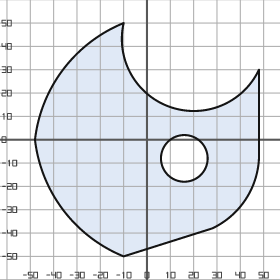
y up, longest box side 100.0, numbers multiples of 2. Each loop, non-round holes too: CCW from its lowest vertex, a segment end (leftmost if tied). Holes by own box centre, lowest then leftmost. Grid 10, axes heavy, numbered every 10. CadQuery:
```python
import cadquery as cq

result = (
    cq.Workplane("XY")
    .moveTo(-10.0, -50.0)
    .lineTo(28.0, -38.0)
    .threePointArc((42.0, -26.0), (48.0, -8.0))
    .lineTo(48.0, 30.0)
    .threePointArc((10.0, 14.0), (-10.0, 50.0))
    .threePointArc((-36.0, 30.0), (-48.0, 0.0))
    .threePointArc((-36.0, -30.0), (-10.0, -50.0))
    .close()
    .moveTo(16.0, -8.0)
    .circle(10.0)
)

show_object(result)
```